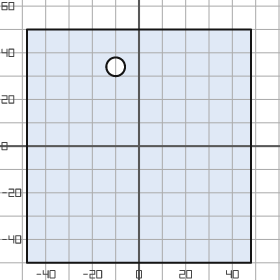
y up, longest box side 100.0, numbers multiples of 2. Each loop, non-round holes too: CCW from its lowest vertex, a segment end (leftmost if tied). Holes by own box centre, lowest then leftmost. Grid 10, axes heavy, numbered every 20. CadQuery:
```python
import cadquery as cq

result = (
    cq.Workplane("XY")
    .moveTo(-48.0, -50.0)
    .lineTo(48.0, -50.0)
    .lineTo(48.0, 50.0)
    .lineTo(-48.0, 50.0)
    .close()
    .moveTo(-10.0, 34.0)
    .circle(4.0)
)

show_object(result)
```